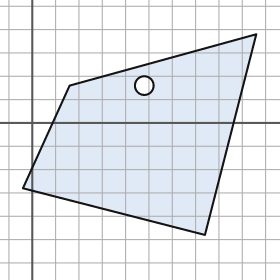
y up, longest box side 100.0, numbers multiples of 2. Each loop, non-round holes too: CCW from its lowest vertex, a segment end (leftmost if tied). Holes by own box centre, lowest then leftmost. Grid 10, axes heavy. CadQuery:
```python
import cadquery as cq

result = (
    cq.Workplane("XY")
    .moveTo(74.0, -48.0)
    .lineTo(96.0, 38.0)
    .lineTo(16.0, 16.0)
    .lineTo(-4.0, -28.0)
    .close()
    .moveTo(48.0, 16.0)
    .circle(4.0)
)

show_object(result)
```